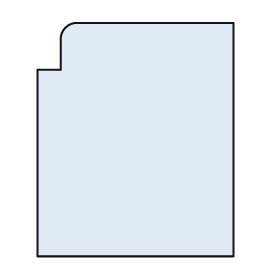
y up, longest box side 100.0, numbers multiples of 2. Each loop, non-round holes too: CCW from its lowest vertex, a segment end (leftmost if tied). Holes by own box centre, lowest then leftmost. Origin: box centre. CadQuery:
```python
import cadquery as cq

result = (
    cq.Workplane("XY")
    .moveTo(-42.0, -50.0)
    .lineTo(42.0, -50.0)
    .lineTo(42.0, 50.0)
    .lineTo(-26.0, 50.0)
    .threePointArc((-30.0, 48.0), (-32.0, 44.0))
    .lineTo(-32.0, 30.0)
    .lineTo(-42.0, 30.0)
    .close()
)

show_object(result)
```